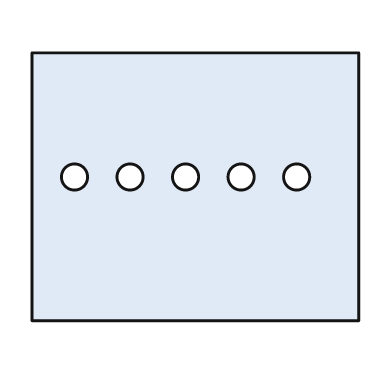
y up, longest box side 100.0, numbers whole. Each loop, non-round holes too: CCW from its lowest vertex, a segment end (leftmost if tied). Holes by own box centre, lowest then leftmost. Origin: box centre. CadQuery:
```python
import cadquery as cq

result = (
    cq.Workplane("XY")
    .moveTo(-50.0, -41.0)
    .lineTo(50.0, -41.0)
    .lineTo(50.0, 41.0)
    .lineTo(-50.0, 41.0)
    .close()
    .moveTo(-37.0, 3.0)
    .circle(4.0)
    .moveTo(-20.0, 3.0)
    .circle(4.0)
    .moveTo(-3.0, 3.0)
    .circle(4.0)
    .moveTo(14.0, 3.0)
    .circle(4.0)
    .moveTo(31.0, 3.0)
    .circle(4.0)
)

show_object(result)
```